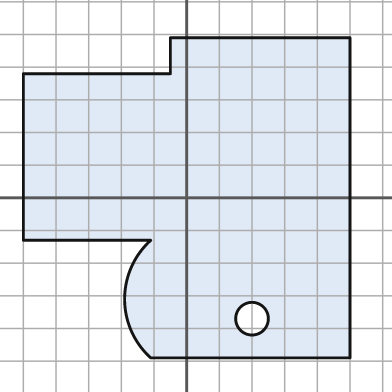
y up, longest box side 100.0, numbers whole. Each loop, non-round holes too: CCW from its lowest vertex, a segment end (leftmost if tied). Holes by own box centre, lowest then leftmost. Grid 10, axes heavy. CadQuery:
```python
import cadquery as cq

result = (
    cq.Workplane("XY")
    .moveTo(-11.0, -49.0)
    .lineTo(50.0, -49.0)
    .lineTo(50.0, 49.0)
    .lineTo(-5.0, 49.0)
    .lineTo(-5.0, 38.0)
    .lineTo(-50.0, 38.0)
    .lineTo(-50.0, -13.0)
    .lineTo(-11.0, -13.0)
    .threePointArc((-19.0, -31.0), (-11.0, -49.0))
    .close()
    .moveTo(20.0, -37.0)
    .circle(5.0)
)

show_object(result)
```